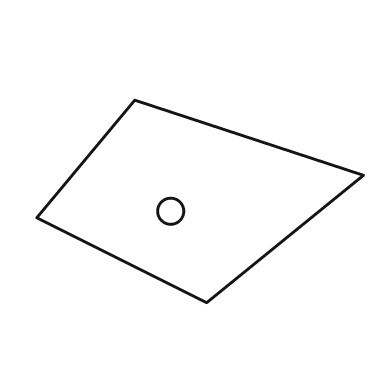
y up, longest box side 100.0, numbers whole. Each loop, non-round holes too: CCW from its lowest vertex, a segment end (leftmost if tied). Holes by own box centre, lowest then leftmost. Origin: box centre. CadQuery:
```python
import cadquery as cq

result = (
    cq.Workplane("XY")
    .moveTo(2.0, -31.0)
    .lineTo(50.0, 8.0)
    .lineTo(-20.0, 31.0)
    .lineTo(-50.0, -5.0)
    .close()
    .moveTo(-9.0, -3.0)
    .circle(4.0)
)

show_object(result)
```